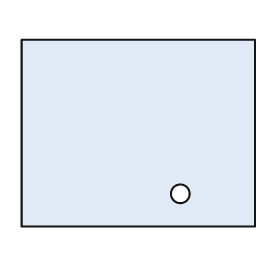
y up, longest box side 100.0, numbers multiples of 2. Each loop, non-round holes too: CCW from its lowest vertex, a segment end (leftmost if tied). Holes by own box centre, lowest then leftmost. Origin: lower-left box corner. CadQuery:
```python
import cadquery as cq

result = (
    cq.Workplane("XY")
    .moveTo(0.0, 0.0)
    .lineTo(100.0, 0.0)
    .lineTo(100.0, 80.0)
    .lineTo(0.0, 80.0)
    .close()
    .moveTo(68.0, 14.0)
    .circle(4.0)
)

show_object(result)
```